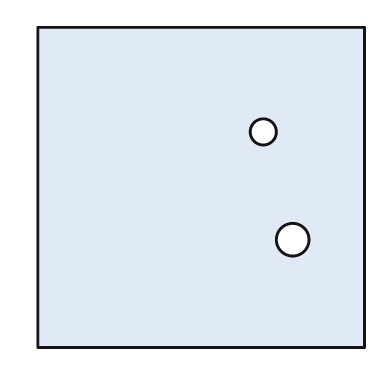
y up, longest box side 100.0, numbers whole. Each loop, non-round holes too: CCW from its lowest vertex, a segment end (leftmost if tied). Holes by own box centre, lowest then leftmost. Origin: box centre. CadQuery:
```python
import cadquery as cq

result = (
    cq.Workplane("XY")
    .moveTo(-50.0, -49.0)
    .lineTo(50.0, -49.0)
    .lineTo(50.0, 49.0)
    .lineTo(-50.0, 49.0)
    .close()
    .moveTo(28.0, -16.0)
    .circle(5.0)
    .moveTo(19.0, 17.0)
    .circle(4.0)
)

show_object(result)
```